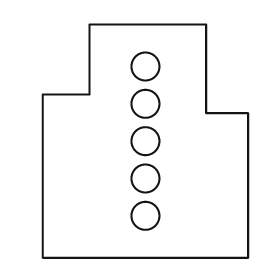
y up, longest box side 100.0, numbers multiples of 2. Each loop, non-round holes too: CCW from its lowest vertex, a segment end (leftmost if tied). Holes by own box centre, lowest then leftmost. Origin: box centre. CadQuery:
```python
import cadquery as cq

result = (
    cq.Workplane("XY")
    .moveTo(-44.0, -50.0)
    .lineTo(44.0, -50.0)
    .lineTo(44.0, 12.0)
    .lineTo(26.0, 12.0)
    .lineTo(26.0, 50.0)
    .lineTo(-24.0, 50.0)
    .lineTo(-24.0, 20.0)
    .lineTo(-44.0, 20.0)
    .close()
    .moveTo(0.0, -32.0)
    .circle(6.0)
    .moveTo(0.0, -16.0)
    .circle(6.0)
    .moveTo(0.0, 0.0)
    .circle(6.0)
    .moveTo(0.0, 16.0)
    .circle(6.0)
    .moveTo(0.0, 32.0)
    .circle(6.0)
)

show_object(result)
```